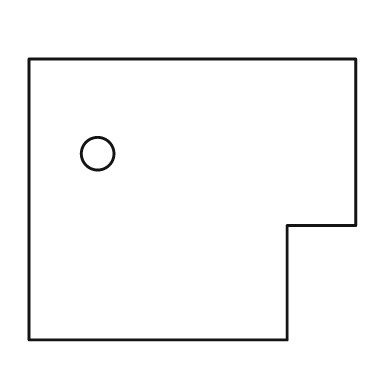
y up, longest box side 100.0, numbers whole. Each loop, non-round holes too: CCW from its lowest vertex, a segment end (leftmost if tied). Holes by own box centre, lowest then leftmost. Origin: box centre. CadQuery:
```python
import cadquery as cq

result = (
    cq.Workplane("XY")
    .moveTo(-50.0, -43.0)
    .lineTo(29.0, -43.0)
    .lineTo(29.0, -8.0)
    .lineTo(50.0, -8.0)
    .lineTo(50.0, 43.0)
    .lineTo(-50.0, 43.0)
    .close()
    .moveTo(-29.0, 14.0)
    .circle(5.0)
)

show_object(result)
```